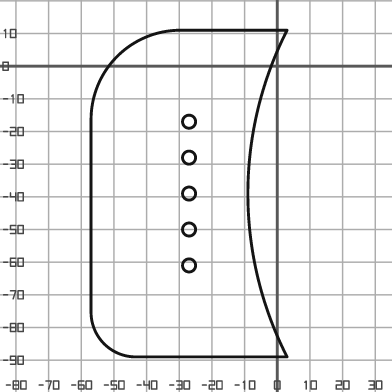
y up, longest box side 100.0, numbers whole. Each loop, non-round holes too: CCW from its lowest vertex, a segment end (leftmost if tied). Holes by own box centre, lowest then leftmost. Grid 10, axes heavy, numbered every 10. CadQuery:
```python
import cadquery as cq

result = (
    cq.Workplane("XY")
    .moveTo(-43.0, -89.0)
    .lineTo(3.0, -89.0)
    .threePointArc((-9.0, -39.0), (3.0, 11.0))
    .lineTo(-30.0, 11.0)
    .threePointArc((-49.0, 3.0), (-57.0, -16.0))
    .lineTo(-57.0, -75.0)
    .threePointArc((-53.0, -85.0), (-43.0, -89.0))
    .close()
    .moveTo(-27.0, -61.0)
    .circle(2.0)
    .moveTo(-27.0, -50.0)
    .circle(2.0)
    .moveTo(-27.0, -39.0)
    .circle(2.0)
    .moveTo(-27.0, -28.0)
    .circle(2.0)
    .moveTo(-27.0, -17.0)
    .circle(2.0)
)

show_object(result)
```